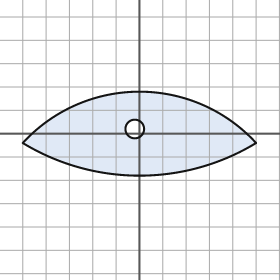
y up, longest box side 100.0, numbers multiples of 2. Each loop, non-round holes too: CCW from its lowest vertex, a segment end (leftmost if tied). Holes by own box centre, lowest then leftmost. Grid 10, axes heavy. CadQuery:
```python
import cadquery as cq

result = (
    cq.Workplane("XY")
    .moveTo(-50.0, -4.0)
    .threePointArc((0.0, -18.0), (50.0, -4.0))
    .threePointArc((0.0, 18.0), (-50.0, -4.0))
    .close()
    .moveTo(-2.0, 2.0)
    .circle(4.0)
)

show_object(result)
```